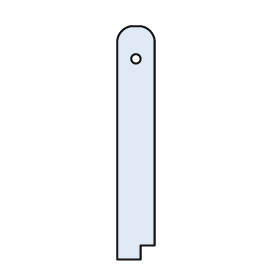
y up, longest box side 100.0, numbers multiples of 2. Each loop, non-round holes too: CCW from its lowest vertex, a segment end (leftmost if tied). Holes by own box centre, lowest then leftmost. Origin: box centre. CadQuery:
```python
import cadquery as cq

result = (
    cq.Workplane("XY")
    .moveTo(-8.0, -50.0)
    .lineTo(2.0, -50.0)
    .lineTo(2.0, -44.0)
    .lineTo(8.0, -44.0)
    .lineTo(8.0, 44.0)
    .threePointArc((6.0, 48.0), (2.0, 50.0))
    .lineTo(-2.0, 50.0)
    .threePointArc((-6.0, 48.0), (-8.0, 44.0))
    .close()
    .moveTo(0.0, 36.0)
    .circle(2.0)
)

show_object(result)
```